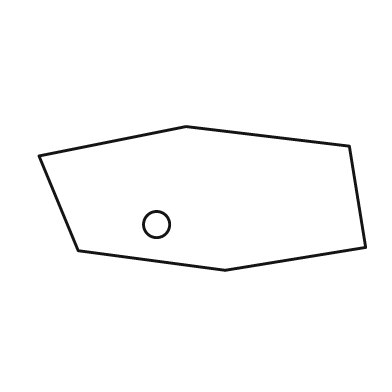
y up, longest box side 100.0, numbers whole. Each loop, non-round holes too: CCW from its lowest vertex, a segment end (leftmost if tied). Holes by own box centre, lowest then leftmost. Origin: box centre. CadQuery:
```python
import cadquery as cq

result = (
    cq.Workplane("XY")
    .moveTo(7.0, -22.0)
    .lineTo(50.0, -15.0)
    .lineTo(45.0, 16.0)
    .lineTo(-5.0, 22.0)
    .lineTo(-50.0, 13.0)
    .lineTo(-38.0, -16.0)
    .close()
    .moveTo(-14.0, -8.0)
    .circle(4.0)
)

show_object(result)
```